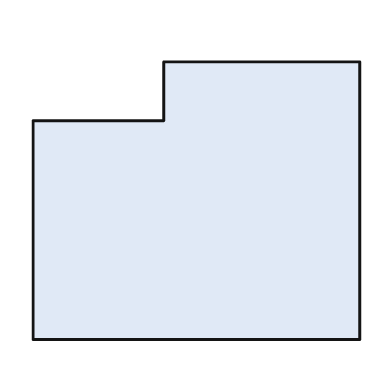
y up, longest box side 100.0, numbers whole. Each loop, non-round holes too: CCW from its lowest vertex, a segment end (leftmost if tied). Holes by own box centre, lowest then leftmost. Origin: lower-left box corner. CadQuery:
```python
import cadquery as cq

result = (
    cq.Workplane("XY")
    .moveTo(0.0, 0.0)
    .lineTo(100.0, 0.0)
    .lineTo(100.0, 85.0)
    .lineTo(40.0, 85.0)
    .lineTo(40.0, 67.0)
    .lineTo(0.0, 67.0)
    .close()
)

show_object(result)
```